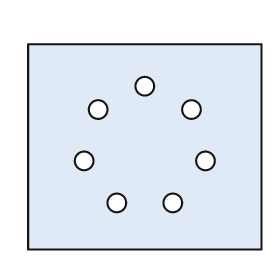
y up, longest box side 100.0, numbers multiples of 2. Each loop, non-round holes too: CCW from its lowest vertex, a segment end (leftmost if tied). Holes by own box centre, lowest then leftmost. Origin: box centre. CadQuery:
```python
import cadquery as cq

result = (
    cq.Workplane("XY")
    .moveTo(-50.0, -44.0)
    .lineTo(50.0, -44.0)
    .lineTo(50.0, 44.0)
    .lineTo(-50.0, 44.0)
    .close()
    .moveTo(-12.0, -24.0)
    .circle(4.0)
    .moveTo(12.0, -24.0)
    .circle(4.0)
    .moveTo(-26.0, -6.0)
    .circle(4.0)
    .moveTo(26.0, -6.0)
    .circle(4.0)
    .moveTo(-20.0, 16.0)
    .circle(4.0)
    .moveTo(20.0, 16.0)
    .circle(4.0)
    .moveTo(0.0, 26.0)
    .circle(4.0)
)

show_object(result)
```